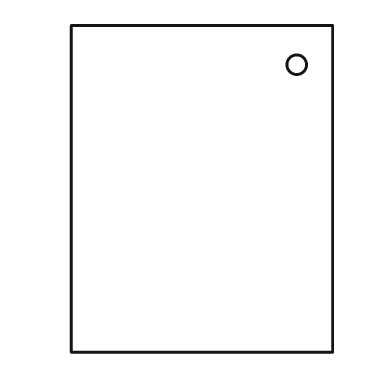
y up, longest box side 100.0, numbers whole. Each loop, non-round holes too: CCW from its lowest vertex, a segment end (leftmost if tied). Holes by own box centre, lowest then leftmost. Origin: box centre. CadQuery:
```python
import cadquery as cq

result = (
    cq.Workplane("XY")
    .moveTo(-40.0, -50.0)
    .lineTo(40.0, -50.0)
    .lineTo(40.0, 50.0)
    .lineTo(-40.0, 50.0)
    .close()
    .moveTo(29.0, 38.0)
    .circle(3.0)
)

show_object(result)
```